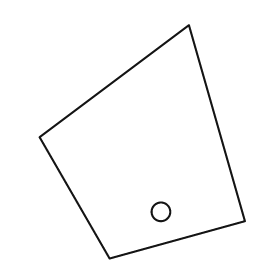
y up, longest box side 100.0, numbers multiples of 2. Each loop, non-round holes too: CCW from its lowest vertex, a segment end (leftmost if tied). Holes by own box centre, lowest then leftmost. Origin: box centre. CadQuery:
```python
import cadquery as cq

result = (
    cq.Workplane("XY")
    .moveTo(-14.0, -50.0)
    .lineTo(44.0, -34.0)
    .lineTo(20.0, 50.0)
    .lineTo(-44.0, 2.0)
    .close()
    .moveTo(8.0, -30.0)
    .circle(4.0)
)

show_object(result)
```